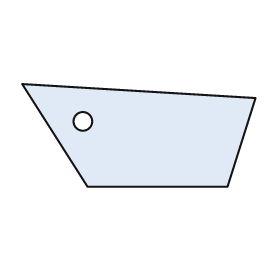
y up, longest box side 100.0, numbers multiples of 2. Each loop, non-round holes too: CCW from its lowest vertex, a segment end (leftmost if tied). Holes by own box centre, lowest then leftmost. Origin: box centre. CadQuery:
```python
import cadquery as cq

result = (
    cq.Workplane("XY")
    .moveTo(-22.0, -22.0)
    .lineTo(38.0, -22.0)
    .lineTo(50.0, 16.0)
    .lineTo(-50.0, 22.0)
    .close()
    .moveTo(-24.0, 6.0)
    .circle(4.0)
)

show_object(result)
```